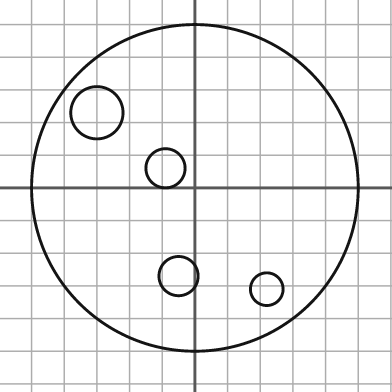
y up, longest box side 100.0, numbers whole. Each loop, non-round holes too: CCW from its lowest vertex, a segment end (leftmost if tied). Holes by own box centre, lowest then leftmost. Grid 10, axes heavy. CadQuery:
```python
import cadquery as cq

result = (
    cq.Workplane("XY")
    .moveTo(0.0, 0.0)
    .circle(50.0)
    .moveTo(22.0, -31.0)
    .circle(5.0)
    .moveTo(-5.0, -27.0)
    .circle(6.0)
    .moveTo(-9.0, 6.0)
    .circle(6.0)
    .moveTo(-30.0, 23.0)
    .circle(8.0)
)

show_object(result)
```